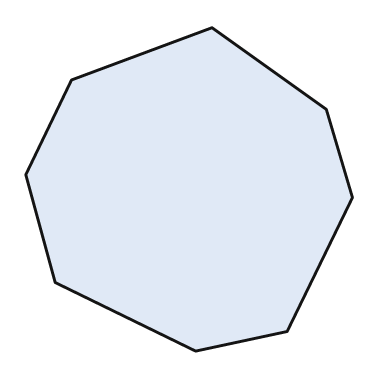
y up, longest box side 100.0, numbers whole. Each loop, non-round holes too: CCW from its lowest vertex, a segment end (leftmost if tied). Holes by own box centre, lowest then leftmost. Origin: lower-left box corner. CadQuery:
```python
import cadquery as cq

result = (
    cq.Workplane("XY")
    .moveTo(52.0, 0.0)
    .lineTo(80.0, 6.0)
    .lineTo(100.0, 47.0)
    .lineTo(92.0, 74.0)
    .lineTo(57.0, 99.0)
    .lineTo(14.0, 83.0)
    .lineTo(0.0, 54.0)
    .lineTo(9.0, 21.0)
    .close()
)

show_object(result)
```